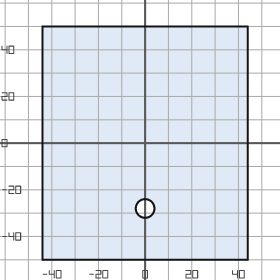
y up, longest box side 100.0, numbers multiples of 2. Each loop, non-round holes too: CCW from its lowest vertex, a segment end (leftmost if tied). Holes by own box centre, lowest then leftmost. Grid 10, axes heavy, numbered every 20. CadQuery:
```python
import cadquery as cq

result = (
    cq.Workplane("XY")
    .moveTo(-44.0, -50.0)
    .lineTo(44.0, -50.0)
    .lineTo(44.0, 50.0)
    .lineTo(-44.0, 50.0)
    .close()
    .moveTo(0.0, -28.0)
    .circle(4.0)
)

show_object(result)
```